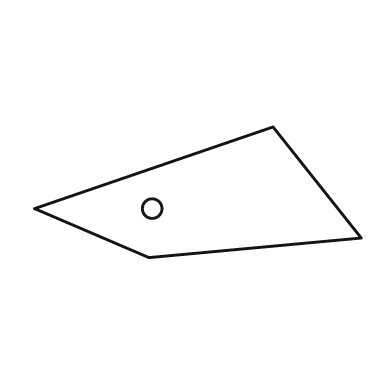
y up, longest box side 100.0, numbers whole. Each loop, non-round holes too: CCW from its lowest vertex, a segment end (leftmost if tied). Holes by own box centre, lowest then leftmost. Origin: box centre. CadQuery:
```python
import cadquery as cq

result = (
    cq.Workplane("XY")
    .moveTo(-15.0, -20.0)
    .lineTo(50.0, -14.0)
    .lineTo(23.0, 20.0)
    .lineTo(-50.0, -5.0)
    .close()
    .moveTo(-14.0, -5.0)
    .circle(3.0)
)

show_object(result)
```